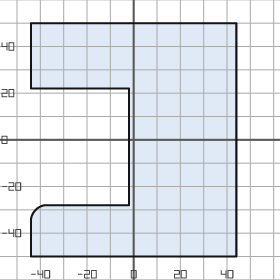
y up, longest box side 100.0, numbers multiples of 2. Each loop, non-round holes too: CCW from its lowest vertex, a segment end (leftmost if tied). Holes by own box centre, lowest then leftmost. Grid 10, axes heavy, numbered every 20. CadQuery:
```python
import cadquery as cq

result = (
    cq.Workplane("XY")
    .moveTo(-44.0, -50.0)
    .lineTo(44.0, -50.0)
    .lineTo(44.0, 50.0)
    .lineTo(-44.0, 50.0)
    .lineTo(-44.0, 22.0)
    .lineTo(-2.0, 22.0)
    .lineTo(-2.0, -28.0)
    .lineTo(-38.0, -28.0)
    .threePointArc((-42.0, -30.0), (-44.0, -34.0))
    .close()
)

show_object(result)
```